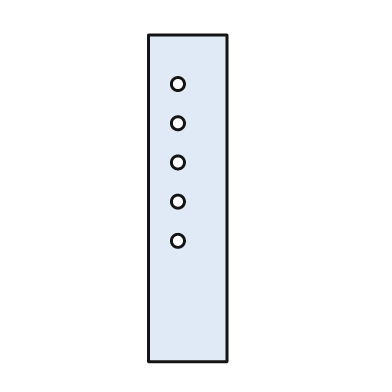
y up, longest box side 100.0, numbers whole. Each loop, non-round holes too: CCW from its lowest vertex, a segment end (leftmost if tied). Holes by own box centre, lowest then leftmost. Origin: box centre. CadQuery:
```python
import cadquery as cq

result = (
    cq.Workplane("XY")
    .moveTo(-12.0, -50.0)
    .lineTo(12.0, -50.0)
    .lineTo(12.0, 50.0)
    .lineTo(-12.0, 50.0)
    .close()
    .moveTo(-3.0, -13.0)
    .circle(2.0)
    .moveTo(-3.0, -1.0)
    .circle(2.0)
    .moveTo(-3.0, 11.0)
    .circle(2.0)
    .moveTo(-3.0, 23.0)
    .circle(2.0)
    .moveTo(-3.0, 35.0)
    .circle(2.0)
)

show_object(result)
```